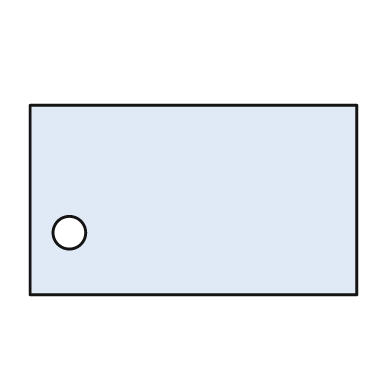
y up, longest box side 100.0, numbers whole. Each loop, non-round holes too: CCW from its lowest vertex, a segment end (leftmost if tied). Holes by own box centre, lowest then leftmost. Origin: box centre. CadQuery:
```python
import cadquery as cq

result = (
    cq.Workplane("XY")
    .moveTo(-50.0, -29.0)
    .lineTo(50.0, -29.0)
    .lineTo(50.0, 29.0)
    .lineTo(-50.0, 29.0)
    .close()
    .moveTo(-38.0, -10.0)
    .circle(5.0)
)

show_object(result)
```